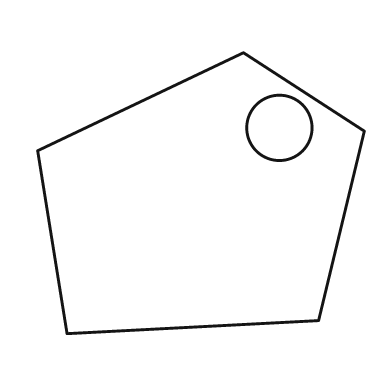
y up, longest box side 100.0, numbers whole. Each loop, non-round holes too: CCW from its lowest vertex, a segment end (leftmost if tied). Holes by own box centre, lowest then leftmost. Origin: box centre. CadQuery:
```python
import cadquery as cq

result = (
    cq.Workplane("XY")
    .moveTo(-41.0, -43.0)
    .lineTo(36.0, -39.0)
    .lineTo(50.0, 19.0)
    .lineTo(13.0, 43.0)
    .lineTo(-50.0, 13.0)
    .close()
    .moveTo(24.0, 20.0)
    .circle(10.0)
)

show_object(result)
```